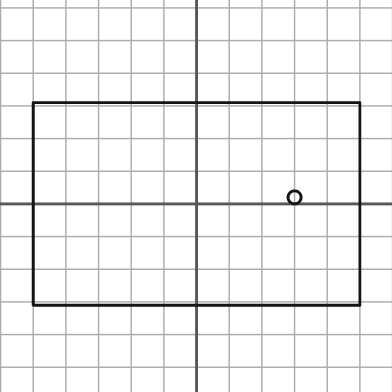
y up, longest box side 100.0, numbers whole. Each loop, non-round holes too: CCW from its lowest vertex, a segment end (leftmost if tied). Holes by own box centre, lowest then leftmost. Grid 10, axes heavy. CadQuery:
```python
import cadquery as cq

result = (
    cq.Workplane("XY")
    .moveTo(-50.0, -31.0)
    .lineTo(50.0, -31.0)
    .lineTo(50.0, 31.0)
    .lineTo(-50.0, 31.0)
    .close()
    .moveTo(30.0, 2.0)
    .circle(2.0)
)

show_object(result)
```